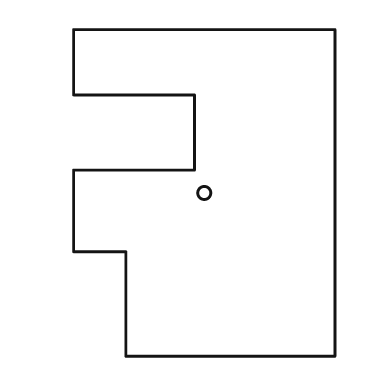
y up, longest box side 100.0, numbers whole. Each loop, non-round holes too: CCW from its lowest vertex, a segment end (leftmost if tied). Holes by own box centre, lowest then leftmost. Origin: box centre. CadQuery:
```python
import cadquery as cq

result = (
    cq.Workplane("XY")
    .moveTo(-24.0, -50.0)
    .lineTo(40.0, -50.0)
    .lineTo(40.0, 50.0)
    .lineTo(-40.0, 50.0)
    .lineTo(-40.0, 30.0)
    .lineTo(-3.0, 30.0)
    .lineTo(-3.0, 7.0)
    .lineTo(-40.0, 7.0)
    .lineTo(-40.0, -18.0)
    .lineTo(-24.0, -18.0)
    .close()
    .moveTo(0.0, 0.0)
    .circle(2.0)
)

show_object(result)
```